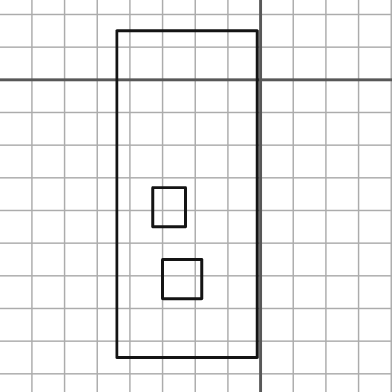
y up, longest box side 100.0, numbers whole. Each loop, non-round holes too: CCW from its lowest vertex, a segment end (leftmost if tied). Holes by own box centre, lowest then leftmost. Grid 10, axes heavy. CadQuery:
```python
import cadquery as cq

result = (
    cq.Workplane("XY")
    .moveTo(-44.0, -85.0)
    .lineTo(-1.0, -85.0)
    .lineTo(-1.0, 15.0)
    .lineTo(-44.0, 15.0)
    .close()
    .moveTo(-30.0, -67.0)
    .lineTo(-18.0, -67.0)
    .lineTo(-18.0, -55.0)
    .lineTo(-30.0, -55.0)
    .close()
    .moveTo(-33.0, -45.0)
    .lineTo(-23.0, -45.0)
    .lineTo(-23.0, -33.0)
    .lineTo(-33.0, -33.0)
    .close()
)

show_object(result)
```